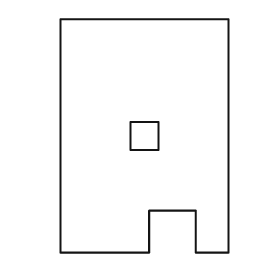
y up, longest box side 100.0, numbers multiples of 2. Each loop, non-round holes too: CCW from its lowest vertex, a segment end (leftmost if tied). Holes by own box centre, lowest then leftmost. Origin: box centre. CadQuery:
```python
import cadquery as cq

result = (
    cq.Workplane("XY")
    .moveTo(-36.0, -50.0)
    .lineTo(2.0, -50.0)
    .lineTo(2.0, -32.0)
    .lineTo(22.0, -32.0)
    .lineTo(22.0, -50.0)
    .lineTo(36.0, -50.0)
    .lineTo(36.0, 50.0)
    .lineTo(-36.0, 50.0)
    .close()
    .moveTo(-6.0, -6.0)
    .lineTo(6.0, -6.0)
    .lineTo(6.0, 6.0)
    .lineTo(-6.0, 6.0)
    .close()
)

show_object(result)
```